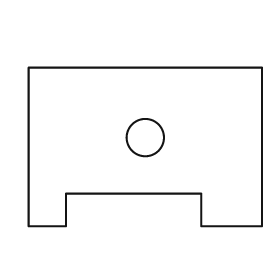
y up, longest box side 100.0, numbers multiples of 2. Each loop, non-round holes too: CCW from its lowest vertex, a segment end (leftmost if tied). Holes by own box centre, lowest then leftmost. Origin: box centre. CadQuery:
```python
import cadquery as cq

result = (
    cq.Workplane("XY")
    .moveTo(-50.0, -34.0)
    .lineTo(-34.0, -34.0)
    .lineTo(-34.0, -20.0)
    .lineTo(24.0, -20.0)
    .lineTo(24.0, -34.0)
    .lineTo(50.0, -34.0)
    .lineTo(50.0, 34.0)
    .lineTo(-50.0, 34.0)
    .close()
    .moveTo(0.0, 4.0)
    .circle(8.0)
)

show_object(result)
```